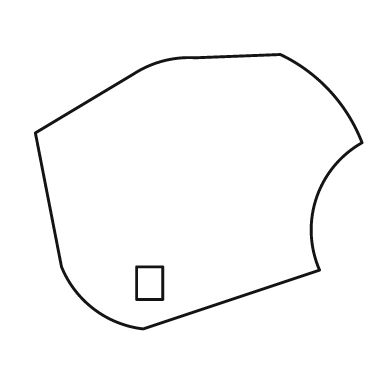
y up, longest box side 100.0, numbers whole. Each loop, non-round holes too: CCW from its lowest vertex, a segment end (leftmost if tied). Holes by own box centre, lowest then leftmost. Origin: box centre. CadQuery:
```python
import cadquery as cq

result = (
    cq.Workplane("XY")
    .moveTo(-17.0, -42.0)
    .lineTo(37.0, -24.0)
    .threePointArc((36.0, -2.0), (50.0, 15.0))
    .threePointArc((40.0, 31.0), (25.0, 42.0))
    .lineTo(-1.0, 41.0)
    .threePointArc((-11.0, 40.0), (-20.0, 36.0))
    .lineTo(-50.0, 18.0)
    .lineTo(-42.0, -23.0)
    .threePointArc((-32.0, -36.0), (-17.0, -42.0))
    .close()
    .moveTo(-19.0, -33.0)
    .lineTo(-11.0, -33.0)
    .lineTo(-11.0, -23.0)
    .lineTo(-19.0, -23.0)
    .close()
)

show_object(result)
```